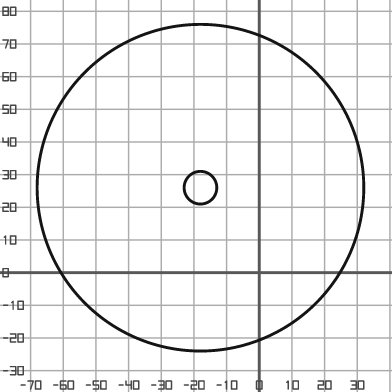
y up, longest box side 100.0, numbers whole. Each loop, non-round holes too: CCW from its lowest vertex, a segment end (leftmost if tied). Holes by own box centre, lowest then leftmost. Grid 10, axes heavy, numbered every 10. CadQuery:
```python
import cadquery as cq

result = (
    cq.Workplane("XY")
    .moveTo(-18.0, 26.0)
    .circle(50.0)
    .moveTo(-18.0, 26.0)
    .circle(5.0)
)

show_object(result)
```